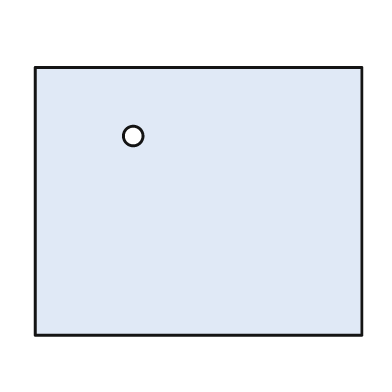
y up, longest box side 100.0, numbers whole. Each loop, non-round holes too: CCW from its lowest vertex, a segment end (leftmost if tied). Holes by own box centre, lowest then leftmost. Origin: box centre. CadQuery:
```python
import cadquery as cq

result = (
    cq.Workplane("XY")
    .moveTo(-50.0, -41.0)
    .lineTo(50.0, -41.0)
    .lineTo(50.0, 41.0)
    .lineTo(-50.0, 41.0)
    .close()
    .moveTo(-20.0, 20.0)
    .circle(3.0)
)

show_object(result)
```